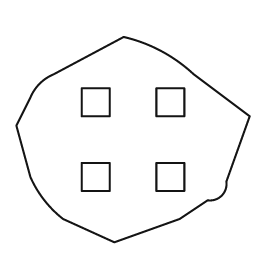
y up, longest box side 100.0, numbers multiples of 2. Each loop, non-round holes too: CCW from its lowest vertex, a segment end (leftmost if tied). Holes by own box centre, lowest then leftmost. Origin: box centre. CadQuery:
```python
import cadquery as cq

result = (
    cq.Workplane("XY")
    .moveTo(-8.0, -44.0)
    .lineTo(20.0, -34.0)
    .lineTo(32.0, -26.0)
    .threePointArc((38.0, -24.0), (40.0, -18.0))
    .lineTo(50.0, 10.0)
    .lineTo(26.0, 28.0)
    .threePointArc((12.0, 38.0), (-4.0, 44.0))
    .lineTo(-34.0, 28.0)
    .threePointArc((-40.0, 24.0), (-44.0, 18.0))
    .lineTo(-50.0, 6.0)
    .lineTo(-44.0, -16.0)
    .threePointArc((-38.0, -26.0), (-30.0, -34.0))
    .close()
    .moveTo(-22.0, -22.0)
    .lineTo(-10.0, -22.0)
    .lineTo(-10.0, -10.0)
    .lineTo(-22.0, -10.0)
    .close()
    .moveTo(10.0, -22.0)
    .lineTo(22.0, -22.0)
    .lineTo(22.0, -10.0)
    .lineTo(10.0, -10.0)
    .close()
    .moveTo(-22.0, 10.0)
    .lineTo(-10.0, 10.0)
    .lineTo(-10.0, 22.0)
    .lineTo(-22.0, 22.0)
    .close()
    .moveTo(10.0, 10.0)
    .lineTo(22.0, 10.0)
    .lineTo(22.0, 22.0)
    .lineTo(10.0, 22.0)
    .close()
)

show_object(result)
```